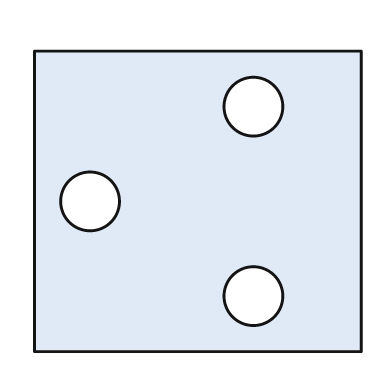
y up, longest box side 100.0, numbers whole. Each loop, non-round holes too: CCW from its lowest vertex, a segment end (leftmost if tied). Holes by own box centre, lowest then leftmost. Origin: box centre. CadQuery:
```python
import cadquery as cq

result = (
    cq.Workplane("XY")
    .moveTo(-50.0, -46.0)
    .lineTo(50.0, -46.0)
    .lineTo(50.0, 46.0)
    .lineTo(-50.0, 46.0)
    .close()
    .moveTo(17.0, -29.0)
    .circle(9.0)
    .moveTo(-33.0, 0.0)
    .circle(9.0)
    .moveTo(17.0, 29.0)
    .circle(9.0)
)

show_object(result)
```